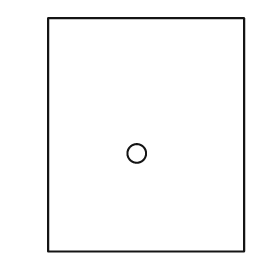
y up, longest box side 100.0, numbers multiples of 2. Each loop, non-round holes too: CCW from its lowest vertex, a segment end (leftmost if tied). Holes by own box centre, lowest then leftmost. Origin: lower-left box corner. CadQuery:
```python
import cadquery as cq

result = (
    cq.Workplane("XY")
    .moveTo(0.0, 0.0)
    .lineTo(84.0, 0.0)
    .lineTo(84.0, 100.0)
    .lineTo(0.0, 100.0)
    .close()
    .moveTo(38.0, 42.0)
    .circle(4.0)
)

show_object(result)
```